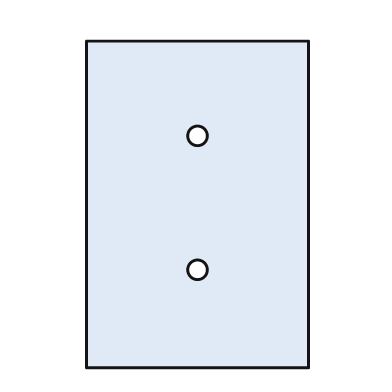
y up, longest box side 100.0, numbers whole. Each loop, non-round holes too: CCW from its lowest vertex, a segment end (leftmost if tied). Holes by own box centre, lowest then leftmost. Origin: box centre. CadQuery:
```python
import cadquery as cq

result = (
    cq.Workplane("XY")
    .moveTo(-34.0, -50.0)
    .lineTo(34.0, -50.0)
    .lineTo(34.0, 50.0)
    .lineTo(-34.0, 50.0)
    .close()
    .moveTo(0.0, -20.0)
    .circle(3.0)
    .moveTo(0.0, 21.0)
    .circle(3.0)
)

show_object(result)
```